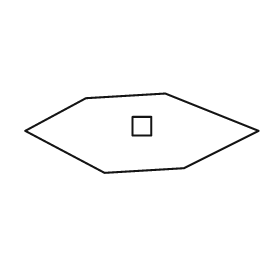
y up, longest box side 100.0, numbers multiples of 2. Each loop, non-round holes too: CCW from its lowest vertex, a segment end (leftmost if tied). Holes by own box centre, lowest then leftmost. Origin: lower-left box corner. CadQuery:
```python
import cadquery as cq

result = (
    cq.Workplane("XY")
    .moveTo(34.0, 0.0)
    .lineTo(68.0, 2.0)
    .lineTo(100.0, 18.0)
    .lineTo(60.0, 34.0)
    .lineTo(26.0, 32.0)
    .lineTo(0.0, 18.0)
    .close()
    .moveTo(46.0, 16.0)
    .lineTo(54.0, 16.0)
    .lineTo(54.0, 24.0)
    .lineTo(46.0, 24.0)
    .close()
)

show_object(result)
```